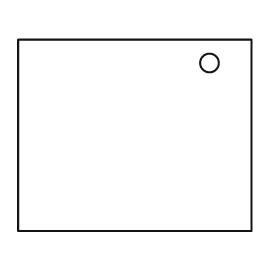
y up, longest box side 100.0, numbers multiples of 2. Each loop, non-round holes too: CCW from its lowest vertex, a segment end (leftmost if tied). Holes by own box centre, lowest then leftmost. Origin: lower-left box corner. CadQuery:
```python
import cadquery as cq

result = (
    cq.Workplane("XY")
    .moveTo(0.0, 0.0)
    .lineTo(100.0, 0.0)
    .lineTo(100.0, 82.0)
    .lineTo(0.0, 82.0)
    .close()
    .moveTo(82.0, 72.0)
    .circle(4.0)
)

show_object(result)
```